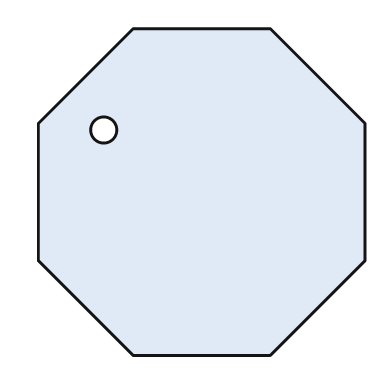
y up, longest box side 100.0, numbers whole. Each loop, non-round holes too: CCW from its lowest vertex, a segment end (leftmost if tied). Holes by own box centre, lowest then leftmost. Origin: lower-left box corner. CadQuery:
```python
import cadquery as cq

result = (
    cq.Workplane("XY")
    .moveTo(29.0, 0.0)
    .lineTo(71.0, 0.0)
    .lineTo(100.0, 29.0)
    .lineTo(100.0, 71.0)
    .lineTo(71.0, 100.0)
    .lineTo(29.0, 100.0)
    .lineTo(0.0, 71.0)
    .lineTo(0.0, 29.0)
    .close()
    .moveTo(20.0, 69.0)
    .circle(4.0)
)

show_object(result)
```